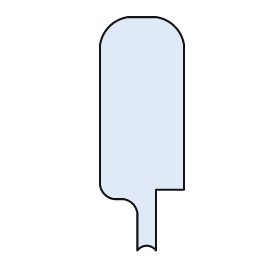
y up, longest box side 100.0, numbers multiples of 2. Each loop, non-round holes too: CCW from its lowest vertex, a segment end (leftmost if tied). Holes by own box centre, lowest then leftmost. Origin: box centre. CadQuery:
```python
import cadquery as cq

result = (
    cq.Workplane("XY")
    .moveTo(-2.0, -50.0)
    .threePointArc((2.0, -48.0), (6.0, -50.0))
    .lineTo(6.0, -24.0)
    .lineTo(18.0, -24.0)
    .lineTo(18.0, 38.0)
    .threePointArc((14.0, 46.0), (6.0, 50.0))
    .lineTo(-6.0, 50.0)
    .threePointArc((-14.0, 46.0), (-18.0, 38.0))
    .lineTo(-18.0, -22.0)
    .threePointArc((-16.0, -26.0), (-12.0, -28.0))
    .lineTo(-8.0, -28.0)
    .threePointArc((-4.0, -30.0), (-2.0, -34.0))
    .close()
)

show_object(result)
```